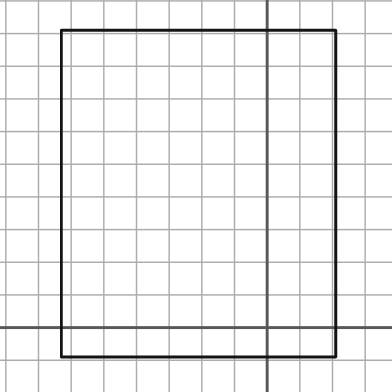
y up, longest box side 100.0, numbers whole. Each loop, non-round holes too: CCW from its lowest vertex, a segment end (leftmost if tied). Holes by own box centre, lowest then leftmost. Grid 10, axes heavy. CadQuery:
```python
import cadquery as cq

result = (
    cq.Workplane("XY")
    .moveTo(-63.0, -9.0)
    .lineTo(21.0, -9.0)
    .lineTo(21.0, 91.0)
    .lineTo(-63.0, 91.0)
    .close()
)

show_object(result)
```